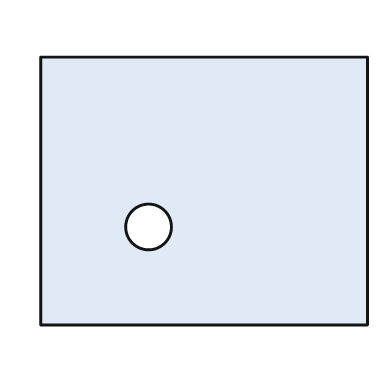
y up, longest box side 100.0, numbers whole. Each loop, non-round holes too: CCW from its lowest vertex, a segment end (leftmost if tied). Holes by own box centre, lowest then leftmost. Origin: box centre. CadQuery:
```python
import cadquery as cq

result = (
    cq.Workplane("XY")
    .moveTo(-50.0, -41.0)
    .lineTo(50.0, -41.0)
    .lineTo(50.0, 41.0)
    .lineTo(-50.0, 41.0)
    .close()
    .moveTo(-17.0, -11.0)
    .circle(7.0)
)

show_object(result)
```